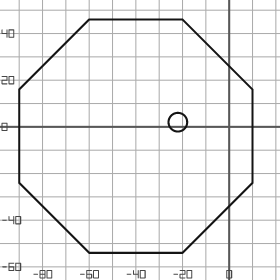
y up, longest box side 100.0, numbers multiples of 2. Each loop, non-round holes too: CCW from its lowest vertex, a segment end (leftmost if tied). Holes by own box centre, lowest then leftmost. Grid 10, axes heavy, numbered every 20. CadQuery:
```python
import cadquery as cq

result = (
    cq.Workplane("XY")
    .moveTo(-60.0, -54.0)
    .lineTo(-20.0, -54.0)
    .lineTo(10.0, -24.0)
    .lineTo(10.0, 16.0)
    .lineTo(-20.0, 46.0)
    .lineTo(-60.0, 46.0)
    .lineTo(-90.0, 16.0)
    .lineTo(-90.0, -24.0)
    .close()
    .moveTo(-22.0, 2.0)
    .circle(4.0)
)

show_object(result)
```